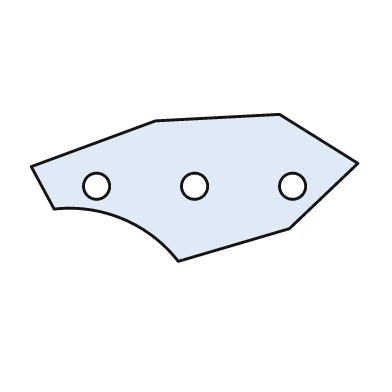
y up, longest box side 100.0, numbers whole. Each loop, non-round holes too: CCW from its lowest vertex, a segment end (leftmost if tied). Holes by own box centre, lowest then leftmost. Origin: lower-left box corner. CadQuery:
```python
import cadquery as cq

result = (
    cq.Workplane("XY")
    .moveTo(45.0, 0.0)
    .lineTo(79.0, 10.0)
    .lineTo(100.0, 30.0)
    .lineTo(76.0, 45.0)
    .lineTo(38.0, 43.0)
    .lineTo(0.0, 29.0)
    .lineTo(7.0, 16.0)
    .threePointArc((28.0, 13.0), (45.0, 0.0))
    .close()
    .moveTo(20.0, 23.0)
    .circle(4.0)
    .moveTo(50.0, 23.0)
    .circle(4.0)
    .moveTo(80.0, 23.0)
    .circle(4.0)
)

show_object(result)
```